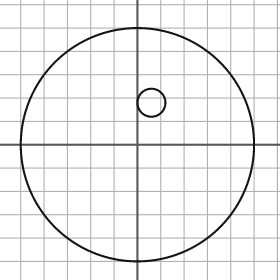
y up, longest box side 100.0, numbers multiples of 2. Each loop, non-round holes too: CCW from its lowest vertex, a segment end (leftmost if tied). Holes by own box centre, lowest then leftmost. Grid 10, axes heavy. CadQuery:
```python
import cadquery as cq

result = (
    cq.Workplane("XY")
    .moveTo(0.0, 0.0)
    .circle(50.0)
    .moveTo(6.0, 18.0)
    .circle(6.0)
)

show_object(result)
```